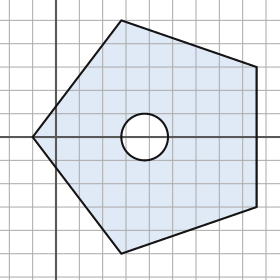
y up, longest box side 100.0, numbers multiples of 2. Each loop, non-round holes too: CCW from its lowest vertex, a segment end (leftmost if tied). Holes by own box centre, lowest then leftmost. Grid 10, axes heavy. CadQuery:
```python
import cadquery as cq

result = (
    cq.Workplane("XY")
    .moveTo(28.0, -50.0)
    .lineTo(86.0, -30.0)
    .lineTo(86.0, 30.0)
    .lineTo(28.0, 50.0)
    .lineTo(-10.0, 0.0)
    .close()
    .moveTo(38.0, 0.0)
    .circle(10.0)
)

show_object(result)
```